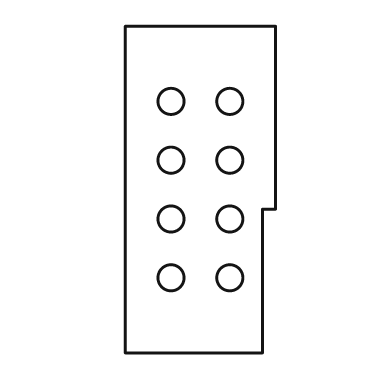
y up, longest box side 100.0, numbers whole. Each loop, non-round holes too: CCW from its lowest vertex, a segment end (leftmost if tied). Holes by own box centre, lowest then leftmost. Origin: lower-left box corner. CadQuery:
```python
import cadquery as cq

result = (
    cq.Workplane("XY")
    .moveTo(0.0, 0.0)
    .lineTo(42.0, 0.0)
    .lineTo(42.0, 44.0)
    .lineTo(46.0, 44.0)
    .lineTo(46.0, 100.0)
    .lineTo(0.0, 100.0)
    .close()
    .moveTo(14.0, 23.0)
    .circle(4.0)
    .moveTo(32.0, 23.0)
    .circle(4.0)
    .moveTo(14.0, 41.0)
    .circle(4.0)
    .moveTo(32.0, 41.0)
    .circle(4.0)
    .moveTo(14.0, 59.0)
    .circle(4.0)
    .moveTo(32.0, 59.0)
    .circle(4.0)
    .moveTo(14.0, 77.0)
    .circle(4.0)
    .moveTo(32.0, 77.0)
    .circle(4.0)
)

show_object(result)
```